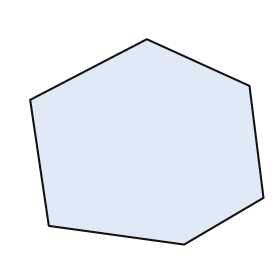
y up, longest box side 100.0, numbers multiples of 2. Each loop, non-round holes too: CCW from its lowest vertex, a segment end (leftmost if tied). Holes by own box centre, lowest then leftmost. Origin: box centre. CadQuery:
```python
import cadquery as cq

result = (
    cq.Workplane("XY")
    .moveTo(16.0, -44.0)
    .lineTo(50.0, -24.0)
    .lineTo(44.0, 24.0)
    .lineTo(0.0, 44.0)
    .lineTo(-50.0, 18.0)
    .lineTo(-42.0, -36.0)
    .close()
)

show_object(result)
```